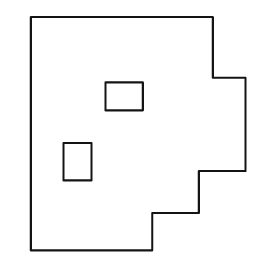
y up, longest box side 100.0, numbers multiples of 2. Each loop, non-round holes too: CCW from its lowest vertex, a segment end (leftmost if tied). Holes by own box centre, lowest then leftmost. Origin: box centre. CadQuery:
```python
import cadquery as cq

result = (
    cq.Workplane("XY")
    .moveTo(-46.0, -50.0)
    .lineTo(6.0, -50.0)
    .lineTo(6.0, -34.0)
    .lineTo(26.0, -34.0)
    .lineTo(26.0, -16.0)
    .lineTo(46.0, -16.0)
    .lineTo(46.0, 24.0)
    .lineTo(32.0, 24.0)
    .lineTo(32.0, 50.0)
    .lineTo(-46.0, 50.0)
    .close()
    .moveTo(-32.0, -20.0)
    .lineTo(-20.0, -20.0)
    .lineTo(-20.0, -4.0)
    .lineTo(-32.0, -4.0)
    .close()
    .moveTo(-14.0, 10.0)
    .lineTo(2.0, 10.0)
    .lineTo(2.0, 22.0)
    .lineTo(-14.0, 22.0)
    .close()
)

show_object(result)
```